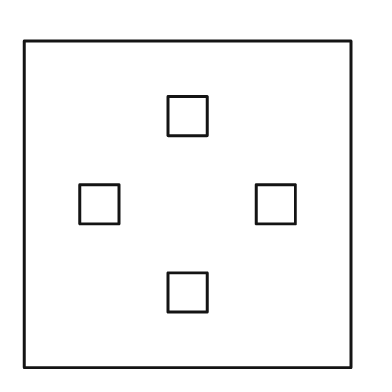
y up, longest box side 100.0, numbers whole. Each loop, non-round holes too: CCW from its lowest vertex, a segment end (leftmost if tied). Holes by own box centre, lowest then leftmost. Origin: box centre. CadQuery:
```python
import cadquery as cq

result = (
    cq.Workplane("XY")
    .moveTo(-50.0, -50.0)
    .lineTo(50.0, -50.0)
    .lineTo(50.0, 50.0)
    .lineTo(-50.0, 50.0)
    .close()
    .moveTo(-6.0, -33.0)
    .lineTo(6.0, -33.0)
    .lineTo(6.0, -21.0)
    .lineTo(-6.0, -21.0)
    .close()
    .moveTo(-33.0, -6.0)
    .lineTo(-21.0, -6.0)
    .lineTo(-21.0, 6.0)
    .lineTo(-33.0, 6.0)
    .close()
    .moveTo(21.0, -6.0)
    .lineTo(33.0, -6.0)
    .lineTo(33.0, 6.0)
    .lineTo(21.0, 6.0)
    .close()
    .moveTo(-6.0, 21.0)
    .lineTo(6.0, 21.0)
    .lineTo(6.0, 33.0)
    .lineTo(-6.0, 33.0)
    .close()
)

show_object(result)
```